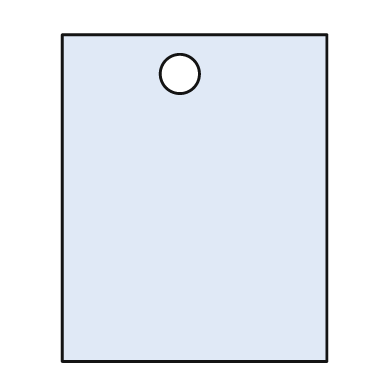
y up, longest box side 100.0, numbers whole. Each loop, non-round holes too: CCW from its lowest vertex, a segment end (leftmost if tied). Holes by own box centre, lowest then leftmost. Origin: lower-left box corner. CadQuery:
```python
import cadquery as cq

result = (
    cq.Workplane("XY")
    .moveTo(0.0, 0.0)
    .lineTo(81.0, 0.0)
    .lineTo(81.0, 100.0)
    .lineTo(0.0, 100.0)
    .close()
    .moveTo(36.0, 88.0)
    .circle(6.0)
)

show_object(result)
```